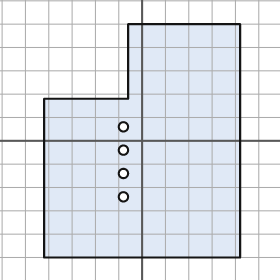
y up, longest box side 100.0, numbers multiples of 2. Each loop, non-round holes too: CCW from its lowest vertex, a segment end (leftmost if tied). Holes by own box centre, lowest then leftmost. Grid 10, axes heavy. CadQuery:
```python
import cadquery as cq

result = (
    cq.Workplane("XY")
    .moveTo(-42.0, -50.0)
    .lineTo(42.0, -50.0)
    .lineTo(42.0, 50.0)
    .lineTo(-6.0, 50.0)
    .lineTo(-6.0, 18.0)
    .lineTo(-42.0, 18.0)
    .close()
    .moveTo(-8.0, -24.0)
    .circle(2.0)
    .moveTo(-8.0, -14.0)
    .circle(2.0)
    .moveTo(-8.0, -4.0)
    .circle(2.0)
    .moveTo(-8.0, 6.0)
    .circle(2.0)
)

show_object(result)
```